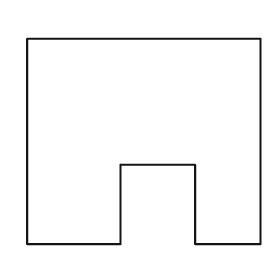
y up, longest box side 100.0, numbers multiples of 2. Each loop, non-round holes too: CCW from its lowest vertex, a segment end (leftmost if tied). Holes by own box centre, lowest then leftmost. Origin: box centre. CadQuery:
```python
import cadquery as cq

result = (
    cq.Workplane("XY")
    .moveTo(-50.0, -44.0)
    .lineTo(-10.0, -44.0)
    .lineTo(-10.0, -10.0)
    .lineTo(22.0, -10.0)
    .lineTo(22.0, -44.0)
    .lineTo(50.0, -44.0)
    .lineTo(50.0, 44.0)
    .lineTo(-50.0, 44.0)
    .close()
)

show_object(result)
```